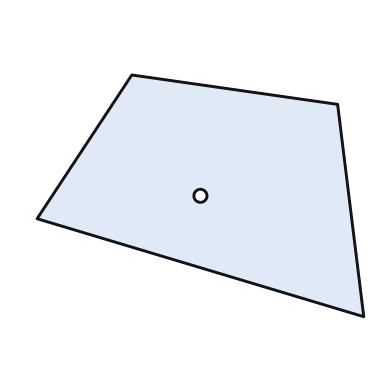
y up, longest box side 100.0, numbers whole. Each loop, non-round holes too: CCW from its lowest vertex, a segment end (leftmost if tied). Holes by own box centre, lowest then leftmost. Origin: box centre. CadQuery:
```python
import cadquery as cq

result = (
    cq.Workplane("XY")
    .moveTo(50.0, -37.0)
    .lineTo(42.0, 28.0)
    .lineTo(-21.0, 37.0)
    .lineTo(-50.0, -7.0)
    .close()
    .moveTo(0.0, 0.0)
    .circle(2.0)
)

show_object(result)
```